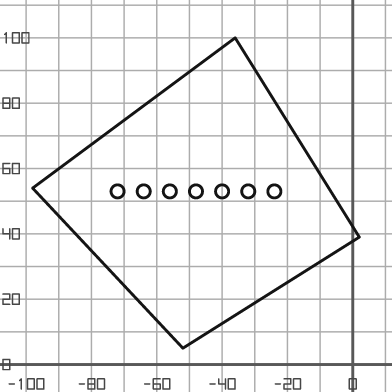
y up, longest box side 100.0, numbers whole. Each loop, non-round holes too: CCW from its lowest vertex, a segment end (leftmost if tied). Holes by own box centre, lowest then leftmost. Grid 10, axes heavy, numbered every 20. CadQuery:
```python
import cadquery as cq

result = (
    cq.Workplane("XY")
    .moveTo(-52.0, 5.0)
    .lineTo(2.0, 39.0)
    .lineTo(-36.0, 100.0)
    .lineTo(-98.0, 54.0)
    .close()
    .moveTo(-72.0, 53.0)
    .circle(2.0)
    .moveTo(-64.0, 53.0)
    .circle(2.0)
    .moveTo(-56.0, 53.0)
    .circle(2.0)
    .moveTo(-48.0, 53.0)
    .circle(2.0)
    .moveTo(-40.0, 53.0)
    .circle(2.0)
    .moveTo(-32.0, 53.0)
    .circle(2.0)
    .moveTo(-24.0, 53.0)
    .circle(2.0)
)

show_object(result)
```